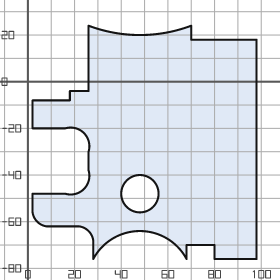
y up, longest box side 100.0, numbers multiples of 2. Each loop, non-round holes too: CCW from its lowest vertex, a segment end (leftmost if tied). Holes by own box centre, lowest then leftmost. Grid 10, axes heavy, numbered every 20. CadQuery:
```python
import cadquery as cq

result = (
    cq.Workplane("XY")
    .moveTo(28.0, -76.0)
    .threePointArc((48.0, -64.0), (68.0, -76.0))
    .lineTo(68.0, -70.0)
    .lineTo(80.0, -70.0)
    .lineTo(80.0, -76.0)
    .lineTo(98.0, -76.0)
    .lineTo(98.0, 18.0)
    .lineTo(70.0, 18.0)
    .lineTo(70.0, 24.0)
    .threePointArc((48.0, 20.0), (26.0, 24.0))
    .lineTo(26.0, -4.0)
    .lineTo(18.0, -4.0)
    .lineTo(18.0, -8.0)
    .lineTo(2.0, -8.0)
    .lineTo(2.0, -20.0)
    .lineTo(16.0, -20.0)
    .threePointArc((24.0, -22.0), (26.0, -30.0))
    .lineTo(26.0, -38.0)
    .threePointArc((24.0, -46.0), (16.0, -48.0))
    .lineTo(2.0, -48.0)
    .lineTo(2.0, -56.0)
    .threePointArc((4.0, -60.0), (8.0, -62.0))
    .lineTo(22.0, -62.0)
    .threePointArc((26.0, -64.0), (28.0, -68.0))
    .close()
    .moveTo(48.0, -48.0)
    .circle(8.0)
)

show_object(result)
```